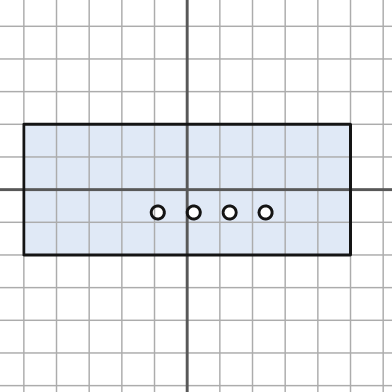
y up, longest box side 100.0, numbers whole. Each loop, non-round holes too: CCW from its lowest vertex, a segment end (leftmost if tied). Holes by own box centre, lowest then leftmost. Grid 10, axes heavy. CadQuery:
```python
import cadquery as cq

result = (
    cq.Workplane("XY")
    .moveTo(-50.0, -20.0)
    .lineTo(50.0, -20.0)
    .lineTo(50.0, 20.0)
    .lineTo(-50.0, 20.0)
    .close()
    .moveTo(-9.0, -7.0)
    .circle(2.0)
    .moveTo(2.0, -7.0)
    .circle(2.0)
    .moveTo(13.0, -7.0)
    .circle(2.0)
    .moveTo(24.0, -7.0)
    .circle(2.0)
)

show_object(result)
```